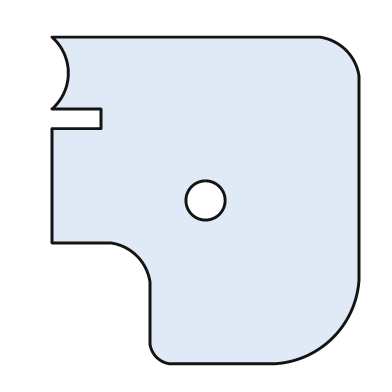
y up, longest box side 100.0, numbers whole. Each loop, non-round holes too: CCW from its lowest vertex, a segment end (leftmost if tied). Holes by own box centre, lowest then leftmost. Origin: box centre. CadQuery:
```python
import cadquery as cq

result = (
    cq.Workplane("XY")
    .moveTo(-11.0, -50.0)
    .lineTo(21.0, -50.0)
    .threePointArc((39.0, -42.0), (47.0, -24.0))
    .lineTo(47.0, 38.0)
    .threePointArc((43.0, 46.0), (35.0, 50.0))
    .lineTo(-47.0, 50.0)
    .threePointArc((-42.0, 39.0), (-47.0, 28.0))
    .lineTo(-32.0, 28.0)
    .lineTo(-32.0, 22.0)
    .lineTo(-47.0, 22.0)
    .lineTo(-47.0, -13.0)
    .lineTo(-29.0, -13.0)
    .threePointArc((-21.0, -17.0), (-17.0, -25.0))
    .lineTo(-17.0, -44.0)
    .threePointArc((-15.0, -48.0), (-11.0, -50.0))
    .close()
    .moveTo(0.0, 0.0)
    .circle(6.0)
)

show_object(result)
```